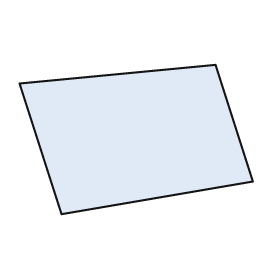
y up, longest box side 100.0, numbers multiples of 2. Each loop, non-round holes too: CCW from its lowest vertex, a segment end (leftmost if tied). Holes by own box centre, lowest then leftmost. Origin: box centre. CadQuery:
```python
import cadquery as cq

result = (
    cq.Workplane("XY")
    .moveTo(-32.0, -32.0)
    .lineTo(50.0, -18.0)
    .lineTo(34.0, 32.0)
    .lineTo(-50.0, 24.0)
    .close()
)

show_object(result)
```